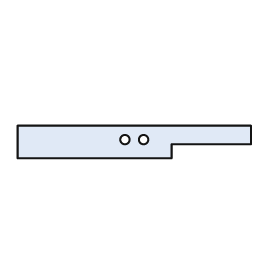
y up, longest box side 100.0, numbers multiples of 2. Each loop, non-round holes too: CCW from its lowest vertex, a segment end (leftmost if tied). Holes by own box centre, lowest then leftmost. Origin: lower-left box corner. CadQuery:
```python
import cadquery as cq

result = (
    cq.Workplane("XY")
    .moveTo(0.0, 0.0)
    .lineTo(66.0, 0.0)
    .lineTo(66.0, 6.0)
    .lineTo(100.0, 6.0)
    .lineTo(100.0, 14.0)
    .lineTo(0.0, 14.0)
    .close()
    .moveTo(46.0, 8.0)
    .circle(2.0)
    .moveTo(54.0, 8.0)
    .circle(2.0)
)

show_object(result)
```